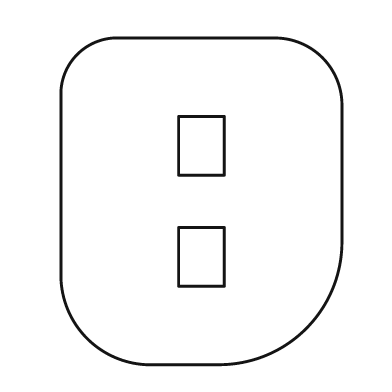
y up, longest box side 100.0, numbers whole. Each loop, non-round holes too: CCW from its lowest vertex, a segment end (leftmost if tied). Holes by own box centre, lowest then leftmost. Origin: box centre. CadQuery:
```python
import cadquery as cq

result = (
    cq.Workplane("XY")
    .moveTo(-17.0, -50.0)
    .lineTo(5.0, -50.0)
    .threePointArc((32.0, -39.0), (43.0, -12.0))
    .lineTo(43.0, 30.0)
    .threePointArc((37.0, 44.0), (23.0, 50.0))
    .lineTo(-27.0, 50.0)
    .threePointArc((-38.0, 45.0), (-43.0, 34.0))
    .lineTo(-43.0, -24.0)
    .threePointArc((-35.0, -42.0), (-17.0, -50.0))
    .close()
    .moveTo(-7.0, -26.0)
    .lineTo(7.0, -26.0)
    .lineTo(7.0, -8.0)
    .lineTo(-7.0, -8.0)
    .close()
    .moveTo(-7.0, 8.0)
    .lineTo(7.0, 8.0)
    .lineTo(7.0, 26.0)
    .lineTo(-7.0, 26.0)
    .close()
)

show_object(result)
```